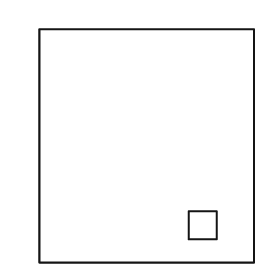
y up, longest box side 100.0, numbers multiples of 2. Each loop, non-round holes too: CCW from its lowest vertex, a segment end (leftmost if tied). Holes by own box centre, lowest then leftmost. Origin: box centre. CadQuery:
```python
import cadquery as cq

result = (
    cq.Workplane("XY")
    .moveTo(-46.0, -50.0)
    .lineTo(46.0, -50.0)
    .lineTo(46.0, 50.0)
    .lineTo(-46.0, 50.0)
    .close()
    .moveTo(18.0, -40.0)
    .lineTo(30.0, -40.0)
    .lineTo(30.0, -28.0)
    .lineTo(18.0, -28.0)
    .close()
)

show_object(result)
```